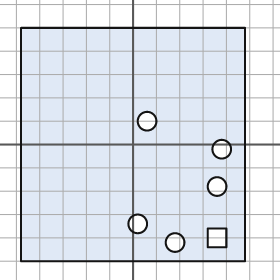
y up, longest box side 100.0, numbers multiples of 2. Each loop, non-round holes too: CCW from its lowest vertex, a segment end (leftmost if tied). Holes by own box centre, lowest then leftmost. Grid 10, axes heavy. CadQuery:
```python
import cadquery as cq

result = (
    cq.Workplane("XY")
    .moveTo(-48.0, -50.0)
    .lineTo(48.0, -50.0)
    .lineTo(48.0, 50.0)
    .lineTo(-48.0, 50.0)
    .close()
    .moveTo(18.0, -42.0)
    .circle(4.0)
    .moveTo(32.0, -44.0)
    .lineTo(40.0, -44.0)
    .lineTo(40.0, -36.0)
    .lineTo(32.0, -36.0)
    .close()
    .moveTo(2.0, -34.0)
    .circle(4.0)
    .moveTo(36.0, -18.0)
    .circle(4.0)
    .moveTo(38.0, -2.0)
    .circle(4.0)
    .moveTo(6.0, 10.0)
    .circle(4.0)
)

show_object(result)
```